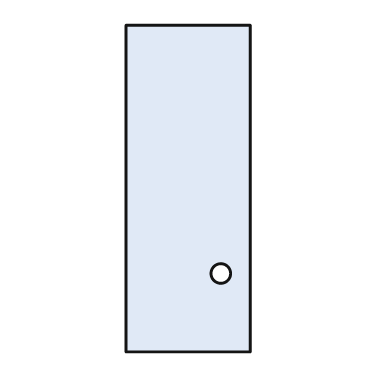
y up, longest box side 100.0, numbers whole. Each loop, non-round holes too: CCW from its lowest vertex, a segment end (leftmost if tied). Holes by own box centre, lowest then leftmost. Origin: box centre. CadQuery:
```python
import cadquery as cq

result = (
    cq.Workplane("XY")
    .moveTo(-19.0, -50.0)
    .lineTo(19.0, -50.0)
    .lineTo(19.0, 50.0)
    .lineTo(-19.0, 50.0)
    .close()
    .moveTo(10.0, -26.0)
    .circle(3.0)
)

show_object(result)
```